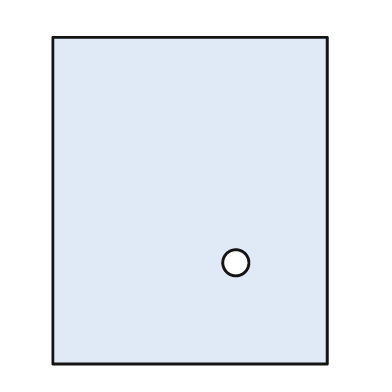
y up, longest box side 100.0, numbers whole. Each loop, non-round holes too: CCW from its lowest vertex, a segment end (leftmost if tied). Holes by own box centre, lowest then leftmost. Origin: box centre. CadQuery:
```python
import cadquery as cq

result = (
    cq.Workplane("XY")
    .moveTo(-42.0, -50.0)
    .lineTo(42.0, -50.0)
    .lineTo(42.0, 50.0)
    .lineTo(-42.0, 50.0)
    .close()
    .moveTo(14.0, -19.0)
    .circle(4.0)
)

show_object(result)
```